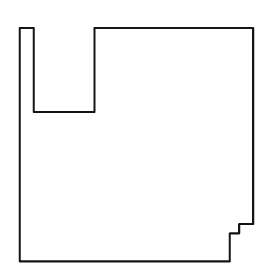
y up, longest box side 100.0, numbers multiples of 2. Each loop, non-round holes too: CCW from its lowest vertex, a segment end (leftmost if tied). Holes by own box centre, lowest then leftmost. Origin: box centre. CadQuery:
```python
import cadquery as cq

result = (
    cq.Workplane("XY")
    .moveTo(-50.0, -50.0)
    .lineTo(40.0, -50.0)
    .lineTo(40.0, -38.0)
    .lineTo(44.0, -38.0)
    .lineTo(44.0, -34.0)
    .lineTo(50.0, -34.0)
    .lineTo(50.0, 50.0)
    .lineTo(-18.0, 50.0)
    .lineTo(-18.0, 14.0)
    .lineTo(-44.0, 14.0)
    .lineTo(-44.0, 50.0)
    .lineTo(-50.0, 50.0)
    .close()
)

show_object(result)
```